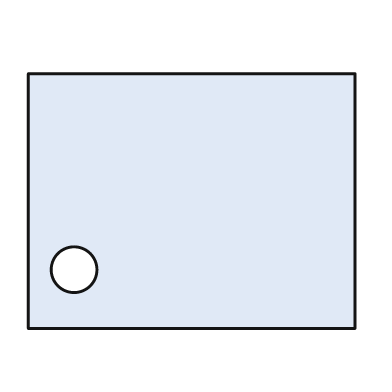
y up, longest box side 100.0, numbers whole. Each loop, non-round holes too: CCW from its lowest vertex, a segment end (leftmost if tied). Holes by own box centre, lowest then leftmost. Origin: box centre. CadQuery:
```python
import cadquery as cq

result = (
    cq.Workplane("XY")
    .moveTo(-50.0, -39.0)
    .lineTo(50.0, -39.0)
    .lineTo(50.0, 39.0)
    .lineTo(-50.0, 39.0)
    .close()
    .moveTo(-36.0, -21.0)
    .circle(7.0)
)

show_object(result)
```